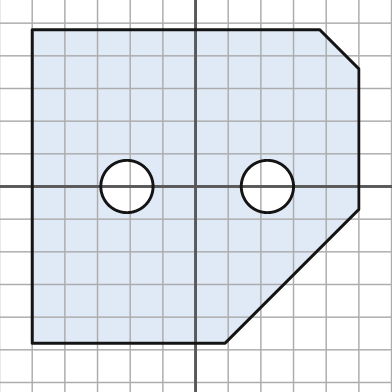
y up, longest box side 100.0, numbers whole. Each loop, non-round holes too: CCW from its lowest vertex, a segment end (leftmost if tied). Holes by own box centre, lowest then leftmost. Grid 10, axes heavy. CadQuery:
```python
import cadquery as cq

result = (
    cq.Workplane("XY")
    .moveTo(-50.0, -48.0)
    .lineTo(9.0, -48.0)
    .lineTo(50.0, -7.0)
    .lineTo(50.0, 36.0)
    .lineTo(38.0, 48.0)
    .lineTo(-50.0, 48.0)
    .close()
    .moveTo(-21.0, 0.0)
    .circle(8.0)
    .moveTo(22.0, 0.0)
    .circle(8.0)
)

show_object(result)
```